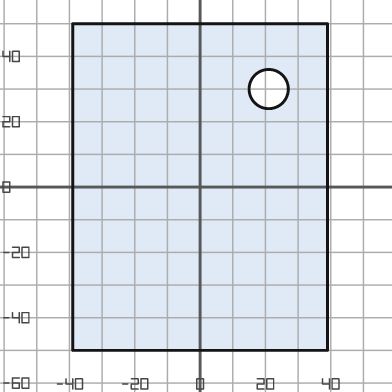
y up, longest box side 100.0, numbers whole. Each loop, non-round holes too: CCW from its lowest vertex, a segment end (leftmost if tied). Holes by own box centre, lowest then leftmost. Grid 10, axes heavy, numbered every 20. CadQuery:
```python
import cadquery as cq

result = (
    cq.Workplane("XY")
    .moveTo(-39.0, -50.0)
    .lineTo(39.0, -50.0)
    .lineTo(39.0, 50.0)
    .lineTo(-39.0, 50.0)
    .close()
    .moveTo(21.0, 30.0)
    .circle(6.0)
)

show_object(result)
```